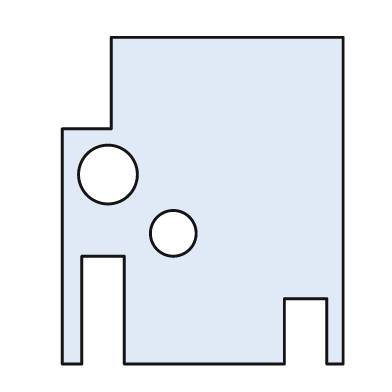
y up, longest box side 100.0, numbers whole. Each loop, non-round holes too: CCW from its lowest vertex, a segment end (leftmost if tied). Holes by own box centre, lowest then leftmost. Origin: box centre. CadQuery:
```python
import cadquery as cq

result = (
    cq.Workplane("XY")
    .moveTo(-43.0, -50.0)
    .lineTo(-37.0, -50.0)
    .lineTo(-37.0, -17.0)
    .lineTo(-24.0, -17.0)
    .lineTo(-24.0, -50.0)
    .lineTo(25.0, -50.0)
    .lineTo(25.0, -30.0)
    .lineTo(38.0, -30.0)
    .lineTo(38.0, -50.0)
    .lineTo(43.0, -50.0)
    .lineTo(43.0, 50.0)
    .lineTo(-28.0, 50.0)
    .lineTo(-28.0, 22.0)
    .lineTo(-43.0, 22.0)
    .close()
    .moveTo(-9.0, -10.0)
    .circle(7.0)
    .moveTo(-29.0, 8.0)
    .circle(9.0)
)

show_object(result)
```